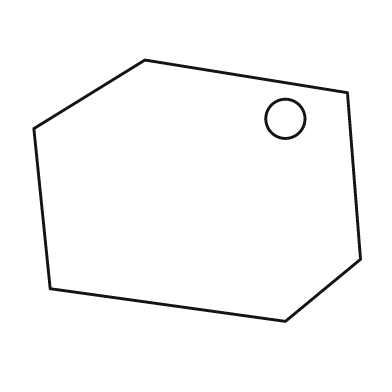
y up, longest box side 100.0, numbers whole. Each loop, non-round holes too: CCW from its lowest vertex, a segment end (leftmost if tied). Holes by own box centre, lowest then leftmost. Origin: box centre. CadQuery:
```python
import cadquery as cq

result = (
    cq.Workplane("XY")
    .moveTo(27.0, -40.0)
    .lineTo(50.0, -21.0)
    .lineTo(46.0, 30.0)
    .lineTo(-16.0, 40.0)
    .lineTo(-50.0, 19.0)
    .lineTo(-45.0, -30.0)
    .close()
    .moveTo(27.0, 22.0)
    .circle(6.0)
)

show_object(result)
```